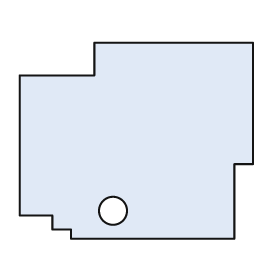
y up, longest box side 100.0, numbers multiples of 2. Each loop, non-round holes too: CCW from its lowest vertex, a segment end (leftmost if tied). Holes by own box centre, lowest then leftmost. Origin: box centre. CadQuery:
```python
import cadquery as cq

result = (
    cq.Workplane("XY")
    .moveTo(-28.0, -42.0)
    .lineTo(42.0, -42.0)
    .lineTo(42.0, -10.0)
    .lineTo(50.0, -10.0)
    .lineTo(50.0, 42.0)
    .lineTo(-18.0, 42.0)
    .lineTo(-18.0, 28.0)
    .lineTo(-50.0, 28.0)
    .lineTo(-50.0, -32.0)
    .lineTo(-36.0, -32.0)
    .lineTo(-36.0, -38.0)
    .lineTo(-28.0, -38.0)
    .close()
    .moveTo(-10.0, -30.0)
    .circle(6.0)
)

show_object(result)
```